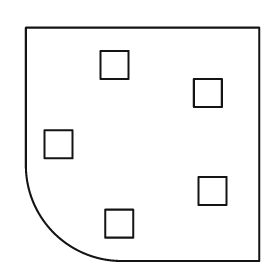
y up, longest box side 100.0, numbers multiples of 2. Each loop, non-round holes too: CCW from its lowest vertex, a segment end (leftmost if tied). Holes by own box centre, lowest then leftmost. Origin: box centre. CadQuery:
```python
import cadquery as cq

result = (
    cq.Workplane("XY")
    .moveTo(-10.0, -50.0)
    .lineTo(50.0, -50.0)
    .lineTo(50.0, 50.0)
    .lineTo(-50.0, 50.0)
    .lineTo(-50.0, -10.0)
    .threePointArc((-38.0, -38.0), (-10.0, -50.0))
    .close()
    .moveTo(-16.0, -40.0)
    .lineTo(-4.0, -40.0)
    .lineTo(-4.0, -28.0)
    .lineTo(-16.0, -28.0)
    .close()
    .moveTo(24.0, -26.0)
    .lineTo(36.0, -26.0)
    .lineTo(36.0, -14.0)
    .lineTo(24.0, -14.0)
    .close()
    .moveTo(-42.0, -6.0)
    .lineTo(-30.0, -6.0)
    .lineTo(-30.0, 6.0)
    .lineTo(-42.0, 6.0)
    .close()
    .moveTo(22.0, 16.0)
    .lineTo(34.0, 16.0)
    .lineTo(34.0, 28.0)
    .lineTo(22.0, 28.0)
    .close()
    .moveTo(-18.0, 28.0)
    .lineTo(-6.0, 28.0)
    .lineTo(-6.0, 40.0)
    .lineTo(-18.0, 40.0)
    .close()
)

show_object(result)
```